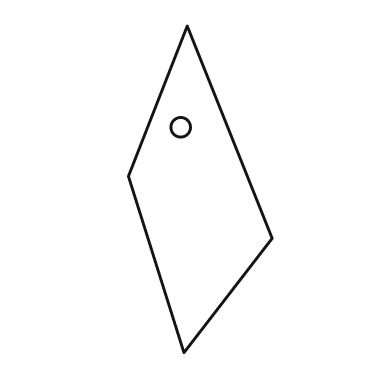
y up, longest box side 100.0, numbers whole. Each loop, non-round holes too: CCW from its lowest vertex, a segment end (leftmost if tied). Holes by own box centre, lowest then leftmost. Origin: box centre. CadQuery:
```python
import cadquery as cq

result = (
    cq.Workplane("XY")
    .moveTo(-5.0, -50.0)
    .lineTo(22.0, -15.0)
    .lineTo(-4.0, 50.0)
    .lineTo(-22.0, 4.0)
    .close()
    .moveTo(-6.0, 19.0)
    .circle(3.0)
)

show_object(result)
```